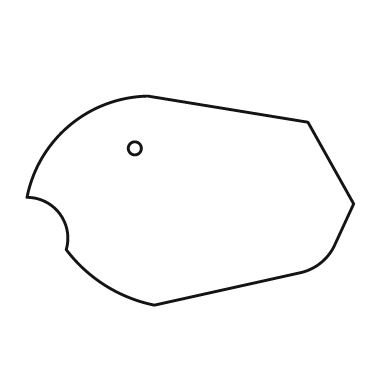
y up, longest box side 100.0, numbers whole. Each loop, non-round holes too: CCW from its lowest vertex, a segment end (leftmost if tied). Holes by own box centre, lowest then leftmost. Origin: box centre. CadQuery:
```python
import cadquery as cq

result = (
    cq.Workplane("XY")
    .moveTo(-11.0, -32.0)
    .lineTo(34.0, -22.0)
    .threePointArc((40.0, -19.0), (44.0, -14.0))
    .lineTo(50.0, -1.0)
    .lineTo(36.0, 24.0)
    .lineTo(-13.0, 32.0)
    .threePointArc((-37.0, 23.0), (-50.0, 1.0))
    .threePointArc((-40.0, -4.0), (-38.0, -15.0))
    .threePointArc((-26.0, -26.0), (-11.0, -32.0))
    .close()
    .moveTo(-17.0, 16.0)
    .circle(2.0)
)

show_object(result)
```